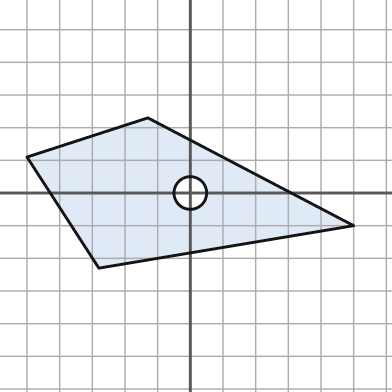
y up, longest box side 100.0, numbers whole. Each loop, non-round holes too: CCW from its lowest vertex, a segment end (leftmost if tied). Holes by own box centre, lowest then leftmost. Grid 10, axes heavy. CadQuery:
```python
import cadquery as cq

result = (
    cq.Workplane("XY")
    .moveTo(-28.0, -23.0)
    .lineTo(50.0, -10.0)
    .lineTo(-13.0, 23.0)
    .lineTo(-50.0, 11.0)
    .close()
    .moveTo(0.0, 0.0)
    .circle(5.0)
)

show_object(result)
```